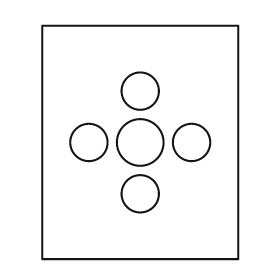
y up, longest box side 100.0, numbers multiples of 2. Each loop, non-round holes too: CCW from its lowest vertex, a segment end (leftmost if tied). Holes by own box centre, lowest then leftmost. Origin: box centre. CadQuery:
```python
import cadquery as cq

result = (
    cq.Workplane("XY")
    .moveTo(-42.0, -50.0)
    .lineTo(42.0, -50.0)
    .lineTo(42.0, 50.0)
    .lineTo(-42.0, 50.0)
    .close()
    .moveTo(0.0, -22.0)
    .circle(8.0)
    .moveTo(-22.0, 0.0)
    .circle(8.0)
    .moveTo(0.0, 0.0)
    .circle(10.0)
    .moveTo(22.0, 0.0)
    .circle(8.0)
    .moveTo(0.0, 22.0)
    .circle(8.0)
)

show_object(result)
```